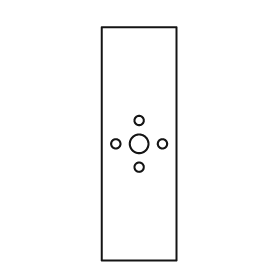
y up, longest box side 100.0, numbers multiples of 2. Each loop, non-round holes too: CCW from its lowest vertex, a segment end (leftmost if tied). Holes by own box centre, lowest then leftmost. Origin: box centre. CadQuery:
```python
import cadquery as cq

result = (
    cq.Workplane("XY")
    .moveTo(-16.0, -50.0)
    .lineTo(16.0, -50.0)
    .lineTo(16.0, 50.0)
    .lineTo(-16.0, 50.0)
    .close()
    .moveTo(0.0, -10.0)
    .circle(2.0)
    .moveTo(-10.0, 0.0)
    .circle(2.0)
    .moveTo(0.0, 0.0)
    .circle(4.0)
    .moveTo(10.0, 0.0)
    .circle(2.0)
    .moveTo(0.0, 10.0)
    .circle(2.0)
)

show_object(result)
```